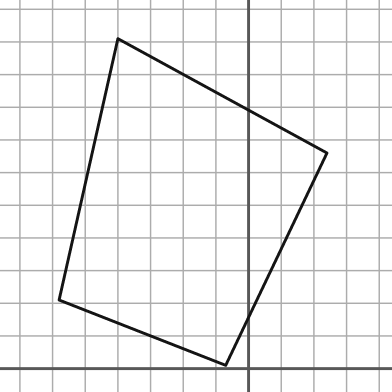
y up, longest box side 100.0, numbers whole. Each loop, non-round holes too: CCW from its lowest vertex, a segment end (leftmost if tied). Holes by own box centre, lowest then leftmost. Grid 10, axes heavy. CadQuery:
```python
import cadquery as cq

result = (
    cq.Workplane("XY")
    .moveTo(-7.0, 1.0)
    .lineTo(24.0, 66.0)
    .lineTo(-40.0, 101.0)
    .lineTo(-58.0, 21.0)
    .close()
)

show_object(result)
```